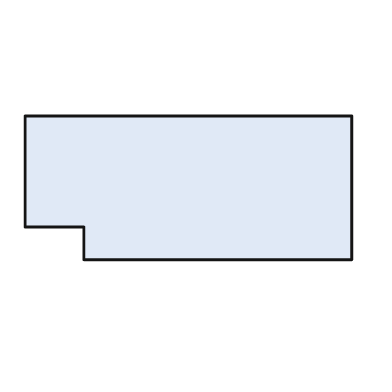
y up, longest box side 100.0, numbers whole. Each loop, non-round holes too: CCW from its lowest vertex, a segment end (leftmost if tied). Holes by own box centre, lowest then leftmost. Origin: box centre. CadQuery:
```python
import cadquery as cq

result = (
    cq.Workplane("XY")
    .moveTo(-32.0, -22.0)
    .lineTo(50.0, -22.0)
    .lineTo(50.0, 22.0)
    .lineTo(-50.0, 22.0)
    .lineTo(-50.0, -12.0)
    .lineTo(-32.0, -12.0)
    .close()
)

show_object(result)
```